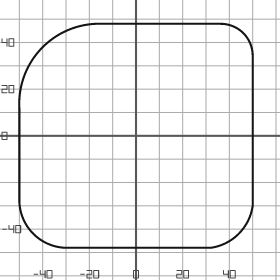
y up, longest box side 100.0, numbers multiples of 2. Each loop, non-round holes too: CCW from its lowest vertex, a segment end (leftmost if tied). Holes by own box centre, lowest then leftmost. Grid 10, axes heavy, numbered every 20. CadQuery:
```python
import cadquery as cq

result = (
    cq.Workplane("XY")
    .moveTo(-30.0, -48.0)
    .lineTo(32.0, -48.0)
    .threePointArc((44.0, -42.0), (50.0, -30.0))
    .lineTo(50.0, 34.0)
    .threePointArc((46.0, 44.0), (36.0, 48.0))
    .lineTo(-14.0, 48.0)
    .threePointArc((-40.0, 38.0), (-50.0, 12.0))
    .lineTo(-50.0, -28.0)
    .threePointArc((-44.0, -42.0), (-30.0, -48.0))
    .close()
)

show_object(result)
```